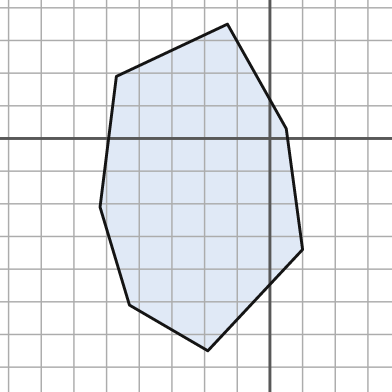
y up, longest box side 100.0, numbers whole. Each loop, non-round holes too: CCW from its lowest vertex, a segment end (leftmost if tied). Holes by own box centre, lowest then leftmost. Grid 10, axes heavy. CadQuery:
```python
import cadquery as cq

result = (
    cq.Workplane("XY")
    .moveTo(-19.0, -65.0)
    .lineTo(10.0, -34.0)
    .lineTo(5.0, 3.0)
    .lineTo(-13.0, 35.0)
    .lineTo(-47.0, 19.0)
    .lineTo(-52.0, -21.0)
    .lineTo(-43.0, -51.0)
    .close()
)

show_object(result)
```